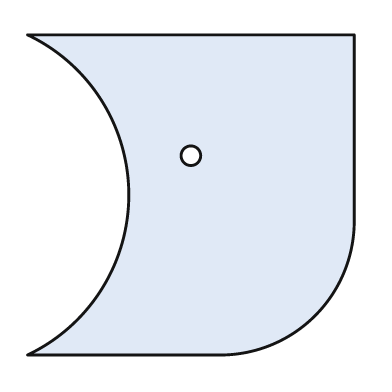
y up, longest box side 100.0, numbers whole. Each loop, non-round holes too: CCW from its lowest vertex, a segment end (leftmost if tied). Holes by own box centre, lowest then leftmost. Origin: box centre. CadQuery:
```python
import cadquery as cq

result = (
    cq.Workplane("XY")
    .moveTo(-50.0, -49.0)
    .lineTo(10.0, -49.0)
    .threePointArc((38.0, -37.0), (50.0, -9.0))
    .lineTo(50.0, 49.0)
    .lineTo(-50.0, 49.0)
    .threePointArc((-19.0, 0.0), (-50.0, -49.0))
    .close()
    .moveTo(0.0, 12.0)
    .circle(3.0)
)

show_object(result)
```